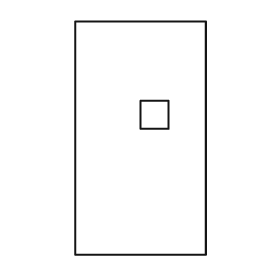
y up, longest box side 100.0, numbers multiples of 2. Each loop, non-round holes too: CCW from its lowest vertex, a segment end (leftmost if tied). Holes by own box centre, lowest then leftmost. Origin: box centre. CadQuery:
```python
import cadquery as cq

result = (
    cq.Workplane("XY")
    .moveTo(-28.0, -50.0)
    .lineTo(28.0, -50.0)
    .lineTo(28.0, 50.0)
    .lineTo(-28.0, 50.0)
    .close()
    .moveTo(0.0, 4.0)
    .lineTo(12.0, 4.0)
    .lineTo(12.0, 16.0)
    .lineTo(0.0, 16.0)
    .close()
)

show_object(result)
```